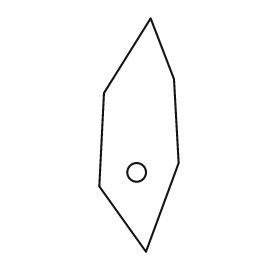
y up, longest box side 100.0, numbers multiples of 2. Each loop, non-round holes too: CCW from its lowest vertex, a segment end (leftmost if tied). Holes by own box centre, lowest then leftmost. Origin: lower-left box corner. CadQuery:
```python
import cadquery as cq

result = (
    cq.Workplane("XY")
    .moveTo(20.0, 0.0)
    .lineTo(34.0, 38.0)
    .lineTo(32.0, 74.0)
    .lineTo(22.0, 100.0)
    .lineTo(2.0, 68.0)
    .lineTo(0.0, 28.0)
    .close()
    .moveTo(16.0, 34.0)
    .circle(4.0)
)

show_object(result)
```